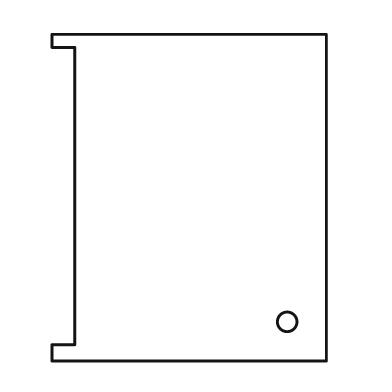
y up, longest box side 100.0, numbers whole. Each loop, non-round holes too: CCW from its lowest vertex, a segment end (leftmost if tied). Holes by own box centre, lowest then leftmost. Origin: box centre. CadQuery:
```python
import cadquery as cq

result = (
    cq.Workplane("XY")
    .moveTo(-42.0, -50.0)
    .lineTo(42.0, -50.0)
    .lineTo(42.0, 50.0)
    .lineTo(-42.0, 50.0)
    .lineTo(-42.0, 46.0)
    .lineTo(-35.0, 46.0)
    .lineTo(-35.0, -45.0)
    .lineTo(-42.0, -45.0)
    .close()
    .moveTo(30.0, -38.0)
    .circle(3.0)
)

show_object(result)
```